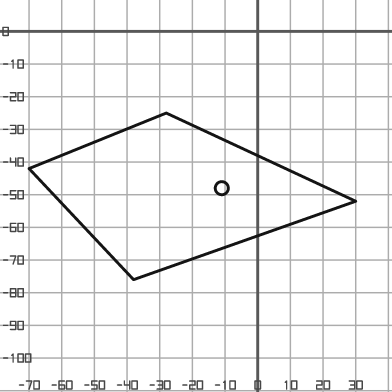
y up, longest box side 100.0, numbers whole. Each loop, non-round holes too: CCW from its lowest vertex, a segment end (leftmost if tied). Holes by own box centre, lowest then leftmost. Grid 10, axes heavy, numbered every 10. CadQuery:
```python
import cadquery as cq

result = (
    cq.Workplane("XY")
    .moveTo(-38.0, -76.0)
    .lineTo(30.0, -52.0)
    .lineTo(-28.0, -25.0)
    .lineTo(-70.0, -42.0)
    .close()
    .moveTo(-11.0, -48.0)
    .circle(2.0)
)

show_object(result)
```